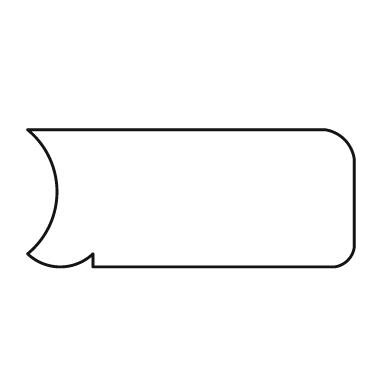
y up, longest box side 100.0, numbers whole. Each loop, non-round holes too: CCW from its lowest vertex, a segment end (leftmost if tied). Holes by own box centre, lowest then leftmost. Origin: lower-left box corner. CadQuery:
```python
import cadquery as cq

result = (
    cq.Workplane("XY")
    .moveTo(20.0, 0.0)
    .lineTo(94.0, 0.0)
    .threePointArc((98.0, 2.0), (100.0, 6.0))
    .lineTo(100.0, 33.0)
    .threePointArc((97.0, 39.0), (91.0, 42.0))
    .lineTo(0.0, 42.0)
    .threePointArc((9.0, 23.0), (0.0, 4.0))
    .threePointArc((10.0, 0.0), (20.0, 4.0))
    .close()
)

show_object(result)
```